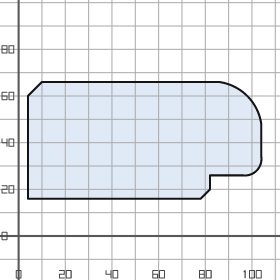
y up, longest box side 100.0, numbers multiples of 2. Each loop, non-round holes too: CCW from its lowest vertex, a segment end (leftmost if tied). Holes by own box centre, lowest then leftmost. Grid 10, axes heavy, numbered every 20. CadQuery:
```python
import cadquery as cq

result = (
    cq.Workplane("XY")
    .moveTo(4.0, 16.0)
    .lineTo(78.0, 16.0)
    .lineTo(82.0, 20.0)
    .lineTo(82.0, 26.0)
    .lineTo(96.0, 26.0)
    .threePointArc((102.0, 28.0), (104.0, 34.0))
    .lineTo(104.0, 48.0)
    .threePointArc((98.0, 60.0), (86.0, 66.0))
    .lineTo(10.0, 66.0)
    .lineTo(4.0, 60.0)
    .close()
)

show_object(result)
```